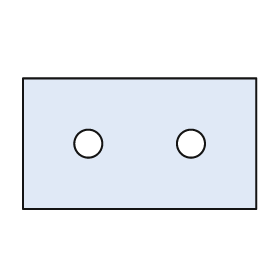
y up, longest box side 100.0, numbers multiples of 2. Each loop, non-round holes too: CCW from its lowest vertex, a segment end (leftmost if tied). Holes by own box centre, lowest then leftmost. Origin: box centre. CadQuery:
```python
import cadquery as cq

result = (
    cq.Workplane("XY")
    .moveTo(-50.0, -28.0)
    .lineTo(50.0, -28.0)
    .lineTo(50.0, 28.0)
    .lineTo(-50.0, 28.0)
    .close()
    .moveTo(-22.0, 0.0)
    .circle(6.0)
    .moveTo(22.0, 0.0)
    .circle(6.0)
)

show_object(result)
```